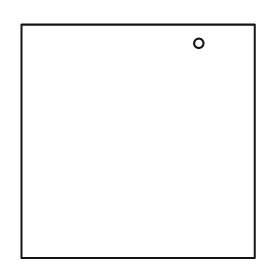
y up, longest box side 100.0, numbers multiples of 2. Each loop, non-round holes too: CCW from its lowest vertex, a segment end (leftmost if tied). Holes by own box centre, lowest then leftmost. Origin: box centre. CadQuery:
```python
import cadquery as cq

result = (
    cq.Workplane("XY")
    .moveTo(-50.0, -50.0)
    .lineTo(50.0, -50.0)
    .lineTo(50.0, 50.0)
    .lineTo(-50.0, 50.0)
    .close()
    .moveTo(26.0, 42.0)
    .circle(2.0)
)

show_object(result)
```